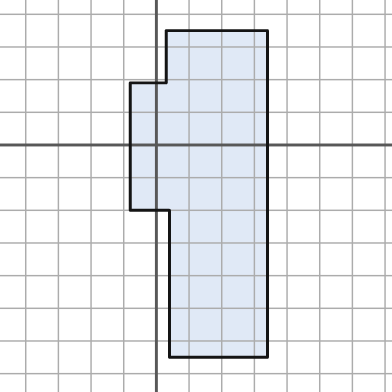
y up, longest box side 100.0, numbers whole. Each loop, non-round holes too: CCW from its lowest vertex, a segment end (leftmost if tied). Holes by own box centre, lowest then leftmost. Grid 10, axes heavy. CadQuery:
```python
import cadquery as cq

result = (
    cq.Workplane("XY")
    .moveTo(4.0, -65.0)
    .lineTo(34.0, -65.0)
    .lineTo(34.0, 35.0)
    .lineTo(3.0, 35.0)
    .lineTo(3.0, 19.0)
    .lineTo(-8.0, 19.0)
    .lineTo(-8.0, -20.0)
    .lineTo(4.0, -20.0)
    .close()
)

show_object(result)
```